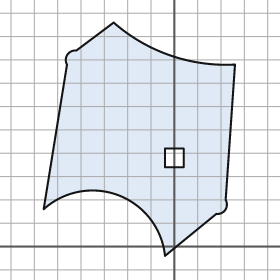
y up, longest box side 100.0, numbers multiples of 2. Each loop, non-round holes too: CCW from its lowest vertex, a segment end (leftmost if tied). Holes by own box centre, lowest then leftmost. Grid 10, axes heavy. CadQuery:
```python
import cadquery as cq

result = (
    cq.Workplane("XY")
    .moveTo(-4.0, -4.0)
    .lineTo(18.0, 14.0)
    .threePointArc((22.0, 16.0), (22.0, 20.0))
    .lineTo(26.0, 78.0)
    .threePointArc((-2.0, 82.0), (-26.0, 96.0))
    .lineTo(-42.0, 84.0)
    .threePointArc((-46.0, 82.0), (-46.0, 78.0))
    .lineTo(-56.0, 16.0)
    .threePointArc((-24.0, 22.0), (-4.0, -4.0))
    .close()
    .moveTo(-4.0, 34.0)
    .lineTo(4.0, 34.0)
    .lineTo(4.0, 42.0)
    .lineTo(-4.0, 42.0)
    .close()
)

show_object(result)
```